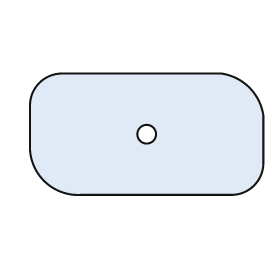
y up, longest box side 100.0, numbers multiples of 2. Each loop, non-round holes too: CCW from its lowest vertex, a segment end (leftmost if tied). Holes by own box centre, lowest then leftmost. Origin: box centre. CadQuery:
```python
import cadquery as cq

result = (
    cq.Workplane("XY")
    .moveTo(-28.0, -26.0)
    .lineTo(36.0, -26.0)
    .threePointArc((46.0, -22.0), (50.0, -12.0))
    .lineTo(50.0, 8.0)
    .threePointArc((44.0, 20.0), (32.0, 26.0))
    .lineTo(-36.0, 26.0)
    .threePointArc((-46.0, 22.0), (-50.0, 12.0))
    .lineTo(-50.0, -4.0)
    .threePointArc((-44.0, -20.0), (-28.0, -26.0))
    .close()
    .moveTo(0.0, 0.0)
    .circle(4.0)
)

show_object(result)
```